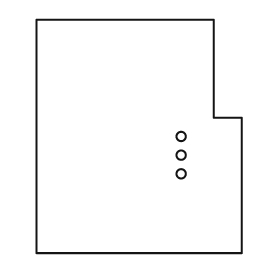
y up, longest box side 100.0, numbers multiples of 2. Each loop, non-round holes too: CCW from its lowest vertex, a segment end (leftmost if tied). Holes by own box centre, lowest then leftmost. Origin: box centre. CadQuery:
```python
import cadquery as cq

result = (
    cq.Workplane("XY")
    .moveTo(-44.0, -50.0)
    .lineTo(44.0, -50.0)
    .lineTo(44.0, 8.0)
    .lineTo(32.0, 8.0)
    .lineTo(32.0, 50.0)
    .lineTo(-44.0, 50.0)
    .close()
    .moveTo(18.0, -16.0)
    .circle(2.0)
    .moveTo(18.0, -8.0)
    .circle(2.0)
    .moveTo(18.0, 0.0)
    .circle(2.0)
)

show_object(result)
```